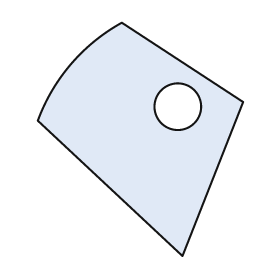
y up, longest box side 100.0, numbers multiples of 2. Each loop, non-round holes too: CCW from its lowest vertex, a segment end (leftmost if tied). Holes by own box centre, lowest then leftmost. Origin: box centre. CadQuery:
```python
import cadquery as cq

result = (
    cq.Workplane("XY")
    .moveTo(18.0, -50.0)
    .lineTo(44.0, 16.0)
    .lineTo(-8.0, 50.0)
    .threePointArc((-30.0, 32.0), (-44.0, 8.0))
    .close()
    .moveTo(16.0, 14.0)
    .circle(10.0)
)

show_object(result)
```